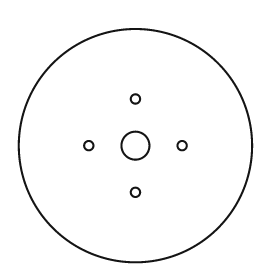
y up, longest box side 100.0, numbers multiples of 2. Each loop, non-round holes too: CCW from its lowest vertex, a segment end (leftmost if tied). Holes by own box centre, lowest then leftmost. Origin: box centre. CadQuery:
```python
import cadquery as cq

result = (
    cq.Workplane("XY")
    .moveTo(0.0, 0.0)
    .circle(50.0)
    .moveTo(0.0, -20.0)
    .circle(2.0)
    .moveTo(-20.0, 0.0)
    .circle(2.0)
    .moveTo(0.0, 0.0)
    .circle(6.0)
    .moveTo(20.0, 0.0)
    .circle(2.0)
    .moveTo(0.0, 20.0)
    .circle(2.0)
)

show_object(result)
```